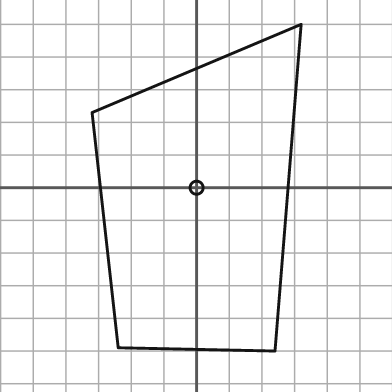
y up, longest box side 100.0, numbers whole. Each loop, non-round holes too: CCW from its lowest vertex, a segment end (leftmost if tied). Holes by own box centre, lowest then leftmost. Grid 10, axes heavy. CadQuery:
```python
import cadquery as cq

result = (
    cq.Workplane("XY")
    .moveTo(24.0, -50.0)
    .lineTo(32.0, 50.0)
    .lineTo(-32.0, 23.0)
    .lineTo(-24.0, -49.0)
    .close()
    .moveTo(0.0, 0.0)
    .circle(2.0)
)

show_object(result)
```